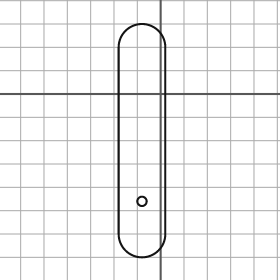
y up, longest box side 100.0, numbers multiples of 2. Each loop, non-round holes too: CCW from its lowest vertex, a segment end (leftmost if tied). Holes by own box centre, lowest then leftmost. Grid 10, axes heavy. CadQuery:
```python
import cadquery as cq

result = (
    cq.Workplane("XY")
    .moveTo(-18.0, -60.0)
    .threePointArc((-8.0, -70.0), (2.0, -60.0))
    .lineTo(2.0, 20.0)
    .threePointArc((-8.0, 30.0), (-18.0, 20.0))
    .close()
    .moveTo(-8.0, -46.0)
    .circle(2.0)
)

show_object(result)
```